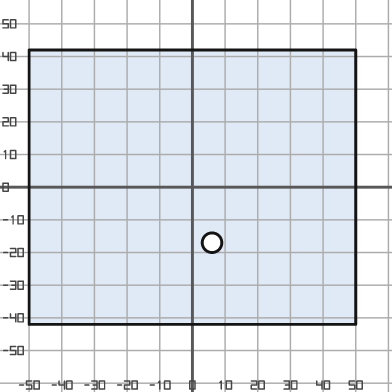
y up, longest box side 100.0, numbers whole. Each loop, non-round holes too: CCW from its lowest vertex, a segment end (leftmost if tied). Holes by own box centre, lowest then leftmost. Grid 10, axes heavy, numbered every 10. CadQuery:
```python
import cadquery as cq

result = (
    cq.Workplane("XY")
    .moveTo(-50.0, -42.0)
    .lineTo(50.0, -42.0)
    .lineTo(50.0, 42.0)
    .lineTo(-50.0, 42.0)
    .close()
    .moveTo(6.0, -17.0)
    .circle(3.0)
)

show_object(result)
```